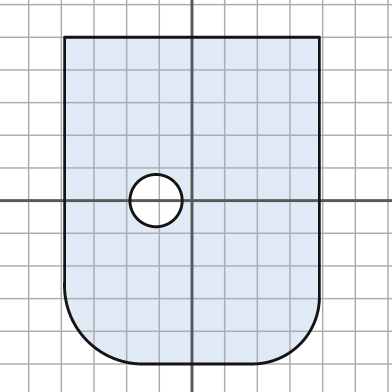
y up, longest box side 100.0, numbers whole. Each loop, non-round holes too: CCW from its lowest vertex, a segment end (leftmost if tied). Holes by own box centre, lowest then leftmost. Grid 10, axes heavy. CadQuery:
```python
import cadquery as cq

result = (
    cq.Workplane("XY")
    .moveTo(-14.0, -50.0)
    .lineTo(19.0, -50.0)
    .threePointArc((33.0, -44.0), (39.0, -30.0))
    .lineTo(39.0, 50.0)
    .lineTo(-39.0, 50.0)
    .lineTo(-39.0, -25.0)
    .threePointArc((-32.0, -43.0), (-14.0, -50.0))
    .close()
    .moveTo(-11.0, 0.0)
    .circle(8.0)
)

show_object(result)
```